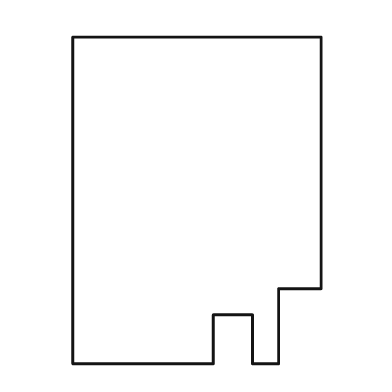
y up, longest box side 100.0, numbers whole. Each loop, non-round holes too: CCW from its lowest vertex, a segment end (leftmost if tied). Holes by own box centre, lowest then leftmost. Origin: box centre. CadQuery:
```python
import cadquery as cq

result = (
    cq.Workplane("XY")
    .moveTo(-38.0, -50.0)
    .lineTo(5.0, -50.0)
    .lineTo(5.0, -35.0)
    .lineTo(17.0, -35.0)
    .lineTo(17.0, -50.0)
    .lineTo(25.0, -50.0)
    .lineTo(25.0, -27.0)
    .lineTo(38.0, -27.0)
    .lineTo(38.0, 50.0)
    .lineTo(-38.0, 50.0)
    .close()
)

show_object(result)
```